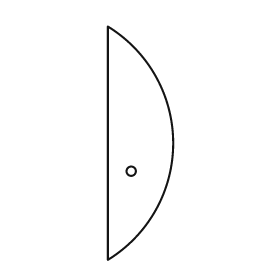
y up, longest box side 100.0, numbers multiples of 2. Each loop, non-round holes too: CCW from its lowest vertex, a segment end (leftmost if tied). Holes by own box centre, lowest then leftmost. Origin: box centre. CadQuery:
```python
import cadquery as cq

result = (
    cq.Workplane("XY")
    .moveTo(-14.0, -50.0)
    .threePointArc((14.0, 0.0), (-14.0, 50.0))
    .close()
    .moveTo(-4.0, -12.0)
    .circle(2.0)
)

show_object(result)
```